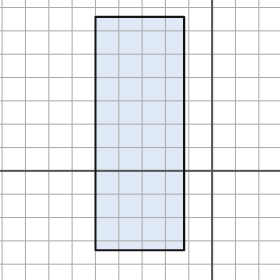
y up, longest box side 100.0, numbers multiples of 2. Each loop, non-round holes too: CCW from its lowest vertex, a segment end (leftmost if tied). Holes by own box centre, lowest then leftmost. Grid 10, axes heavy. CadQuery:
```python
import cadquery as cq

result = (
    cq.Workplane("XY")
    .moveTo(-50.0, -34.0)
    .lineTo(-12.0, -34.0)
    .lineTo(-12.0, 66.0)
    .lineTo(-50.0, 66.0)
    .close()
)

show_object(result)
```